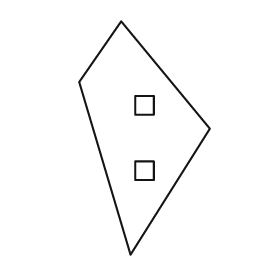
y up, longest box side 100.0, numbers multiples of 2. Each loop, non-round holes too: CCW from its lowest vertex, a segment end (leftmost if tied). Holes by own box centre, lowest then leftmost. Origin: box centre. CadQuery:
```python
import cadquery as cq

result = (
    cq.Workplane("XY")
    .moveTo(-6.0, -50.0)
    .lineTo(28.0, 4.0)
    .lineTo(-10.0, 50.0)
    .lineTo(-28.0, 24.0)
    .close()
    .moveTo(-4.0, -18.0)
    .lineTo(4.0, -18.0)
    .lineTo(4.0, -10.0)
    .lineTo(-4.0, -10.0)
    .close()
    .moveTo(-4.0, 10.0)
    .lineTo(4.0, 10.0)
    .lineTo(4.0, 18.0)
    .lineTo(-4.0, 18.0)
    .close()
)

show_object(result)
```